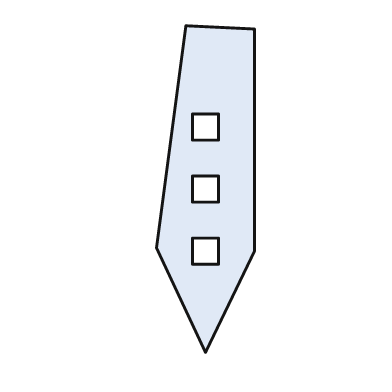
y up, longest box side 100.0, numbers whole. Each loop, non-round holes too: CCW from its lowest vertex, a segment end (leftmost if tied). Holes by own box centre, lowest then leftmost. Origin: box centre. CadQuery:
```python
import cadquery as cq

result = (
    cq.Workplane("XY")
    .moveTo(0.0, -50.0)
    .lineTo(15.0, -19.0)
    .lineTo(15.0, 49.0)
    .lineTo(-6.0, 50.0)
    .lineTo(-15.0, -18.0)
    .close()
    .moveTo(-4.0, -23.0)
    .lineTo(4.0, -23.0)
    .lineTo(4.0, -15.0)
    .lineTo(-4.0, -15.0)
    .close()
    .moveTo(-4.0, -4.0)
    .lineTo(4.0, -4.0)
    .lineTo(4.0, 4.0)
    .lineTo(-4.0, 4.0)
    .close()
    .moveTo(-4.0, 15.0)
    .lineTo(4.0, 15.0)
    .lineTo(4.0, 23.0)
    .lineTo(-4.0, 23.0)
    .close()
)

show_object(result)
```